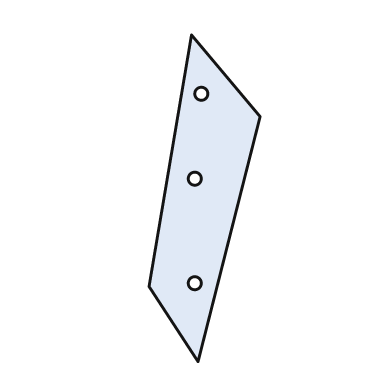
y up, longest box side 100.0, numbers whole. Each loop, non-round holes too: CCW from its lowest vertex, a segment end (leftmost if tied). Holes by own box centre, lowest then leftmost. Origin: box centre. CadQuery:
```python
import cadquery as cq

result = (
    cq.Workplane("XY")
    .moveTo(-2.0, -50.0)
    .lineTo(17.0, 25.0)
    .lineTo(-4.0, 50.0)
    .lineTo(-17.0, -27.0)
    .close()
    .moveTo(-3.0, -26.0)
    .circle(2.0)
    .moveTo(-3.0, 6.0)
    .circle(2.0)
    .moveTo(-1.0, 32.0)
    .circle(2.0)
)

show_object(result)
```